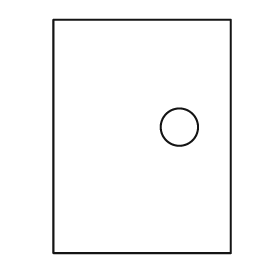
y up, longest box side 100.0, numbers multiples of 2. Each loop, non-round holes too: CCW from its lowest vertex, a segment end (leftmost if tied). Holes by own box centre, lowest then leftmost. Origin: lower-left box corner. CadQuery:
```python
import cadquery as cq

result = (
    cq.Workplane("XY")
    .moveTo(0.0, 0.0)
    .lineTo(76.0, 0.0)
    .lineTo(76.0, 100.0)
    .lineTo(0.0, 100.0)
    .close()
    .moveTo(54.0, 54.0)
    .circle(8.0)
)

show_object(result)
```